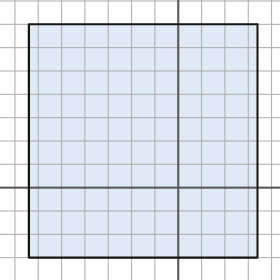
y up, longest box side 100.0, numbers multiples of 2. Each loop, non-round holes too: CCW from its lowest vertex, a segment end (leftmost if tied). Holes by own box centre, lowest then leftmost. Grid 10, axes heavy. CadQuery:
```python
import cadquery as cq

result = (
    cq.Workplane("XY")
    .moveTo(-64.0, -30.0)
    .lineTo(34.0, -30.0)
    .lineTo(34.0, 70.0)
    .lineTo(-64.0, 70.0)
    .close()
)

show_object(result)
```